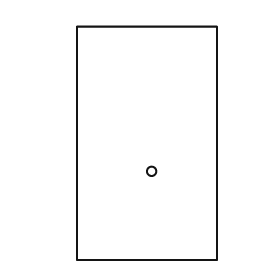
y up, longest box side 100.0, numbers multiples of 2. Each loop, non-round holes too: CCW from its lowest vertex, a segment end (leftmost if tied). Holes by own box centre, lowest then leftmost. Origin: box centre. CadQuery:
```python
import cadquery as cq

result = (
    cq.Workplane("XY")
    .moveTo(-30.0, -50.0)
    .lineTo(30.0, -50.0)
    .lineTo(30.0, 50.0)
    .lineTo(-30.0, 50.0)
    .close()
    .moveTo(2.0, -12.0)
    .circle(2.0)
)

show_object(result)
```